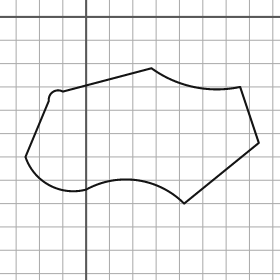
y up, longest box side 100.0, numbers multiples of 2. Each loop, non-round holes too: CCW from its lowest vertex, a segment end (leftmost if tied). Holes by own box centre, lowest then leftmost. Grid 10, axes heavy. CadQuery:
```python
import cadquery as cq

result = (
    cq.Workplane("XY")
    .moveTo(42.0, -80.0)
    .lineTo(74.0, -54.0)
    .lineTo(66.0, -30.0)
    .threePointArc((46.0, -30.0), (28.0, -22.0))
    .lineTo(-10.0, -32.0)
    .threePointArc((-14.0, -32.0), (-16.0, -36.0))
    .lineTo(-26.0, -60.0)
    .threePointArc((-16.0, -72.0), (0.0, -74.0))
    .threePointArc((22.0, -70.0), (42.0, -80.0))
    .close()
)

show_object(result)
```